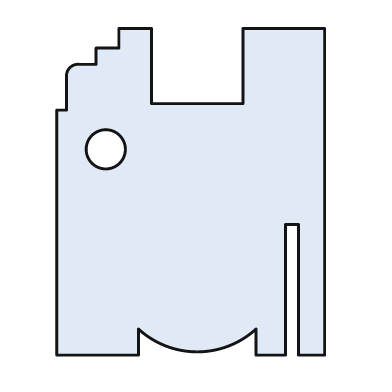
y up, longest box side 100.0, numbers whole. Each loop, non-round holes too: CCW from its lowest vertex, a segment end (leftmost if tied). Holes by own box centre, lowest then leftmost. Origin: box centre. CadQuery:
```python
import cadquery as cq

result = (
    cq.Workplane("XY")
    .moveTo(-41.0, -50.0)
    .lineTo(-16.0, -50.0)
    .lineTo(-16.0, -42.0)
    .threePointArc((2.0, -49.0), (20.0, -42.0))
    .lineTo(20.0, -50.0)
    .lineTo(29.0, -50.0)
    .lineTo(29.0, -10.0)
    .lineTo(33.0, -10.0)
    .lineTo(33.0, -50.0)
    .lineTo(41.0, -50.0)
    .lineTo(41.0, 50.0)
    .lineTo(16.0, 50.0)
    .lineTo(16.0, 27.0)
    .lineTo(-12.0, 27.0)
    .lineTo(-12.0, 50.0)
    .lineTo(-22.0, 50.0)
    .lineTo(-22.0, 44.0)
    .lineTo(-29.0, 44.0)
    .lineTo(-29.0, 39.0)
    .lineTo(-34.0, 39.0)
    .threePointArc((-37.0, 38.0), (-38.0, 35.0))
    .lineTo(-38.0, 25.0)
    .lineTo(-41.0, 25.0)
    .close()
    .moveTo(-26.0, 13.0)
    .circle(6.0)
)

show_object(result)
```